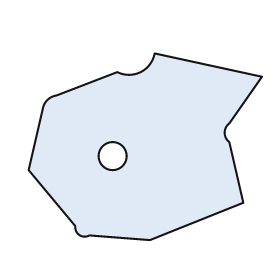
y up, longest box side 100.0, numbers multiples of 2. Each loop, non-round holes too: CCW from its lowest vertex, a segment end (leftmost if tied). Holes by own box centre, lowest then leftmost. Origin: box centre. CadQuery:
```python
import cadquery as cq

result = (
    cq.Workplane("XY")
    .moveTo(2.0, -40.0)
    .lineTo(42.0, -24.0)
    .lineTo(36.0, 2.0)
    .threePointArc((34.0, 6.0), (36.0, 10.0))
    .lineTo(50.0, 30.0)
    .lineTo(4.0, 40.0)
    .threePointArc((-2.0, 32.0), (-12.0, 32.0))
    .lineTo(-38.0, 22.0)
    .threePointArc((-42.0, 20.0), (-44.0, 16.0))
    .lineTo(-50.0, -10.0)
    .lineTo(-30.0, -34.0)
    .threePointArc((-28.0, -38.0), (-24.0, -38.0))
    .close()
    .moveTo(-14.0, -4.0)
    .circle(6.0)
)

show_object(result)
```